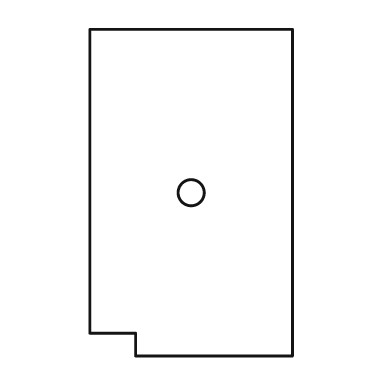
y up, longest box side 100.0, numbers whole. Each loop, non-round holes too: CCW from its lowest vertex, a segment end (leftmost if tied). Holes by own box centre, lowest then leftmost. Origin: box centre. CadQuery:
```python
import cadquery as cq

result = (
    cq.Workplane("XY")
    .moveTo(-17.0, -50.0)
    .lineTo(31.0, -50.0)
    .lineTo(31.0, 50.0)
    .lineTo(-31.0, 50.0)
    .lineTo(-31.0, -43.0)
    .lineTo(-17.0, -43.0)
    .close()
    .moveTo(0.0, 0.0)
    .circle(4.0)
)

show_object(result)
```